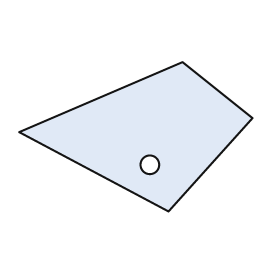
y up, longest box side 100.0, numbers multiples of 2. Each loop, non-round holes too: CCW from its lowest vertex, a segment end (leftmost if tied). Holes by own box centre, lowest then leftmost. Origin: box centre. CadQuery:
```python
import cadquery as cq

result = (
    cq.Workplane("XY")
    .moveTo(14.0, -32.0)
    .lineTo(50.0, 8.0)
    .lineTo(20.0, 32.0)
    .lineTo(-50.0, 2.0)
    .close()
    .moveTo(6.0, -12.0)
    .circle(4.0)
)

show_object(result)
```